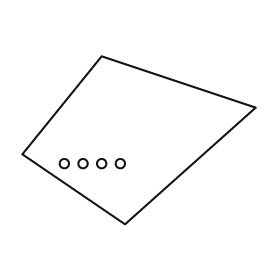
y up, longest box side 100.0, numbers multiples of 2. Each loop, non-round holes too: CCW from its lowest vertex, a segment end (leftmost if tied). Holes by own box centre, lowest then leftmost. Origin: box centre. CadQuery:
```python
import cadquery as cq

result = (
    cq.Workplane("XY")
    .moveTo(-6.0, -36.0)
    .lineTo(50.0, 14.0)
    .lineTo(-16.0, 36.0)
    .lineTo(-50.0, -6.0)
    .close()
    .moveTo(-32.0, -10.0)
    .circle(2.0)
    .moveTo(-24.0, -10.0)
    .circle(2.0)
    .moveTo(-16.0, -10.0)
    .circle(2.0)
    .moveTo(-8.0, -10.0)
    .circle(2.0)
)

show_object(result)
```